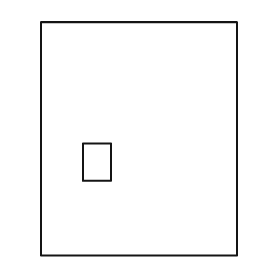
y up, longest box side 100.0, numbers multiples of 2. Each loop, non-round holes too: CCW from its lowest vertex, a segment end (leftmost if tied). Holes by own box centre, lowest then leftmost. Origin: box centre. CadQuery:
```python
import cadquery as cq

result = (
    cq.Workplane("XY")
    .moveTo(-42.0, -50.0)
    .lineTo(42.0, -50.0)
    .lineTo(42.0, 50.0)
    .lineTo(-42.0, 50.0)
    .close()
    .moveTo(-24.0, -18.0)
    .lineTo(-12.0, -18.0)
    .lineTo(-12.0, -2.0)
    .lineTo(-24.0, -2.0)
    .close()
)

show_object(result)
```